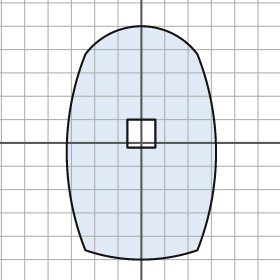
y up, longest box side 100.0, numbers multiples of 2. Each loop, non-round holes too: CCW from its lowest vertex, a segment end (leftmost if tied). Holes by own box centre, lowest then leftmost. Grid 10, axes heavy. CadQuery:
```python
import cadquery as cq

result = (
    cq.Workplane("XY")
    .moveTo(-24.0, -46.0)
    .threePointArc((0.0, -50.0), (24.0, -46.0))
    .threePointArc((32.0, -4.0), (24.0, 38.0))
    .threePointArc((0.0, 50.0), (-24.0, 38.0))
    .threePointArc((-32.0, -4.0), (-24.0, -46.0))
    .close()
    .moveTo(-6.0, -2.0)
    .lineTo(6.0, -2.0)
    .lineTo(6.0, 10.0)
    .lineTo(-6.0, 10.0)
    .close()
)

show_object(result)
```